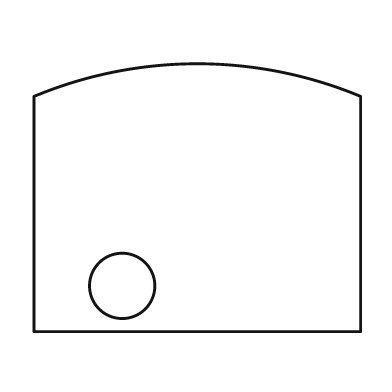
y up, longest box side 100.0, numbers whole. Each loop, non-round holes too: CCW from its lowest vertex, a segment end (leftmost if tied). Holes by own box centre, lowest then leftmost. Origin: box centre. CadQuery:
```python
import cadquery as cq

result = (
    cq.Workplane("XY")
    .moveTo(-50.0, -41.0)
    .lineTo(50.0, -41.0)
    .lineTo(50.0, 31.0)
    .threePointArc((0.0, 41.0), (-50.0, 31.0))
    .close()
    .moveTo(-23.0, -27.0)
    .circle(10.0)
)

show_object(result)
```